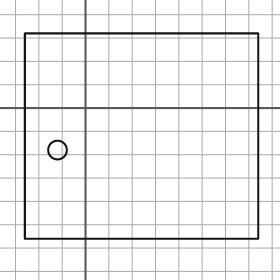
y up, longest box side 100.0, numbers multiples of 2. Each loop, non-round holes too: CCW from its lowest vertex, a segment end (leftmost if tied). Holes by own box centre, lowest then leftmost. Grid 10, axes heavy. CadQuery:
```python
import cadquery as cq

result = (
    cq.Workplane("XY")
    .moveTo(-26.0, -56.0)
    .lineTo(74.0, -56.0)
    .lineTo(74.0, 32.0)
    .lineTo(-26.0, 32.0)
    .close()
    .moveTo(-12.0, -18.0)
    .circle(4.0)
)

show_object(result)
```